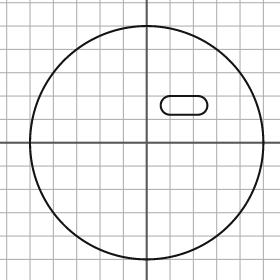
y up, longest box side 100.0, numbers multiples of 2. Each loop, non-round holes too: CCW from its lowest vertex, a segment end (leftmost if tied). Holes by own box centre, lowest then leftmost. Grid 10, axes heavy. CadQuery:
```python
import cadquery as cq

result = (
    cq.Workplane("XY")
    .moveTo(0.0, 0.0)
    .circle(50.0)
    .moveTo(10.0, 12.0)
    .lineTo(22.0, 12.0)
    .threePointArc((26.0, 16.0), (22.0, 20.0))
    .lineTo(10.0, 20.0)
    .threePointArc((6.0, 16.0), (10.0, 12.0))
    .close()
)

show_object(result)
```